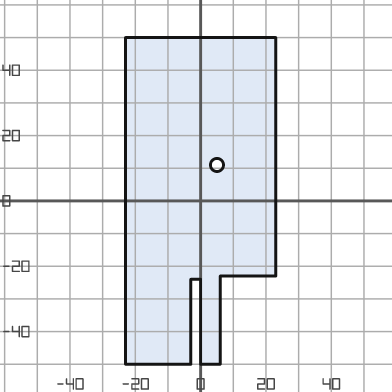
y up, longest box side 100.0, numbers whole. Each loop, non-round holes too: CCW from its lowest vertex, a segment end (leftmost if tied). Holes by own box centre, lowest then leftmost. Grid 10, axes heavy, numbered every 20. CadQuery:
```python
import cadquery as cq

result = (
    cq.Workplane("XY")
    .moveTo(-23.0, -50.0)
    .lineTo(-3.0, -50.0)
    .lineTo(-3.0, -24.0)
    .lineTo(0.0, -24.0)
    .lineTo(0.0, -50.0)
    .lineTo(6.0, -50.0)
    .lineTo(6.0, -23.0)
    .lineTo(23.0, -23.0)
    .lineTo(23.0, 50.0)
    .lineTo(-23.0, 50.0)
    .close()
    .moveTo(5.0, 11.0)
    .circle(2.0)
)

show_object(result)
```